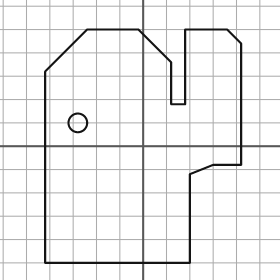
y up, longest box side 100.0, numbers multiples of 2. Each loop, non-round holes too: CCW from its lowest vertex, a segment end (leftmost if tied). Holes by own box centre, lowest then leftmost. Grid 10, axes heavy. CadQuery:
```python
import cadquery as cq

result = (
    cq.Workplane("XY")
    .moveTo(-42.0, -50.0)
    .lineTo(20.0, -50.0)
    .lineTo(20.0, -12.0)
    .lineTo(30.0, -8.0)
    .lineTo(42.0, -8.0)
    .lineTo(42.0, 44.0)
    .lineTo(36.0, 50.0)
    .lineTo(18.0, 50.0)
    .lineTo(18.0, 18.0)
    .lineTo(12.0, 18.0)
    .lineTo(12.0, 36.0)
    .lineTo(-2.0, 50.0)
    .lineTo(-24.0, 50.0)
    .lineTo(-42.0, 32.0)
    .close()
    .moveTo(-28.0, 10.0)
    .circle(4.0)
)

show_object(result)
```